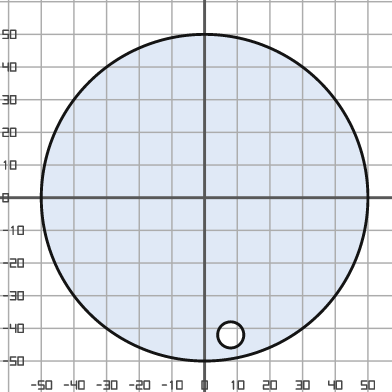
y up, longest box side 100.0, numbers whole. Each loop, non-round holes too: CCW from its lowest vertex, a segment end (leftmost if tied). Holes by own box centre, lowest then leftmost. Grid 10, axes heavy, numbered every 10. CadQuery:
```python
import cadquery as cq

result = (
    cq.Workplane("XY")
    .moveTo(0.0, 0.0)
    .circle(50.0)
    .moveTo(8.0, -42.0)
    .circle(4.0)
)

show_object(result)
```